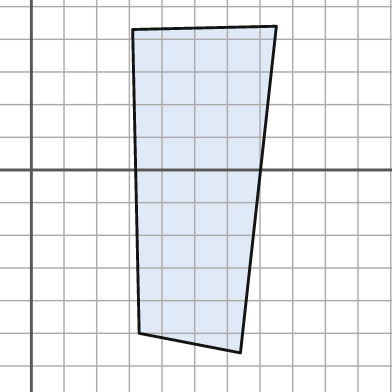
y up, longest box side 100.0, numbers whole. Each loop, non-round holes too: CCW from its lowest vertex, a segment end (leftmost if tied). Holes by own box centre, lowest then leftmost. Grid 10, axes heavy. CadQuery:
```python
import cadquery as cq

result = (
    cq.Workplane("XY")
    .moveTo(64.0, -56.0)
    .lineTo(75.0, 44.0)
    .lineTo(31.0, 43.0)
    .lineTo(33.0, -50.0)
    .close()
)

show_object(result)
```